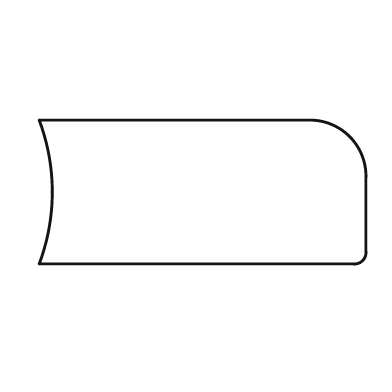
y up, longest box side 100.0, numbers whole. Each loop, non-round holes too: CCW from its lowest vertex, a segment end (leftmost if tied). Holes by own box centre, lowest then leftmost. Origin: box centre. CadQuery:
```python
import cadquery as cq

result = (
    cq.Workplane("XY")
    .moveTo(-50.0, -22.0)
    .lineTo(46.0, -22.0)
    .threePointArc((49.0, -21.0), (50.0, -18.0))
    .lineTo(50.0, 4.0)
    .threePointArc((45.0, 17.0), (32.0, 22.0))
    .lineTo(-50.0, 22.0)
    .threePointArc((-46.0, 0.0), (-50.0, -22.0))
    .close()
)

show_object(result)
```